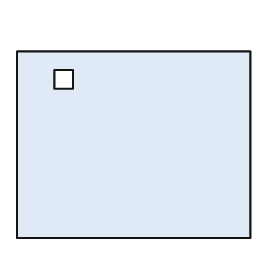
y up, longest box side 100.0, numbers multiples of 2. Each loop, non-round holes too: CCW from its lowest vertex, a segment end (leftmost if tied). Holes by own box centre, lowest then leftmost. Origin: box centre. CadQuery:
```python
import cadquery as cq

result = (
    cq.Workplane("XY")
    .moveTo(-50.0, -40.0)
    .lineTo(50.0, -40.0)
    .lineTo(50.0, 40.0)
    .lineTo(-50.0, 40.0)
    .close()
    .moveTo(-34.0, 24.0)
    .lineTo(-26.0, 24.0)
    .lineTo(-26.0, 32.0)
    .lineTo(-34.0, 32.0)
    .close()
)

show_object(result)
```